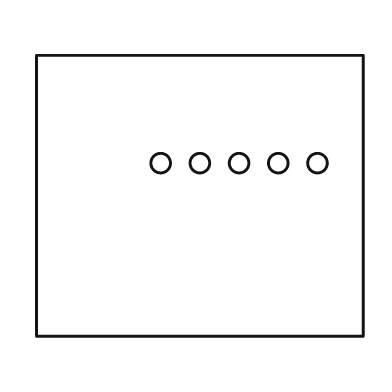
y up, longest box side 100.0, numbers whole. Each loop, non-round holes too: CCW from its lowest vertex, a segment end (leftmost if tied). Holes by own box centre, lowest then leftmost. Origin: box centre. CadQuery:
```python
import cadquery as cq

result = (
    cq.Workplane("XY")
    .moveTo(-50.0, -43.0)
    .lineTo(50.0, -43.0)
    .lineTo(50.0, 43.0)
    .lineTo(-50.0, 43.0)
    .close()
    .moveTo(-12.0, 10.0)
    .circle(3.0)
    .moveTo(0.0, 10.0)
    .circle(3.0)
    .moveTo(12.0, 10.0)
    .circle(3.0)
    .moveTo(24.0, 10.0)
    .circle(3.0)
    .moveTo(36.0, 10.0)
    .circle(3.0)
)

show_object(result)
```